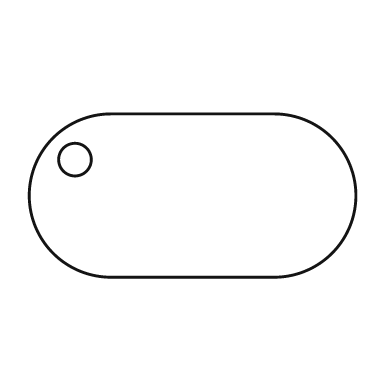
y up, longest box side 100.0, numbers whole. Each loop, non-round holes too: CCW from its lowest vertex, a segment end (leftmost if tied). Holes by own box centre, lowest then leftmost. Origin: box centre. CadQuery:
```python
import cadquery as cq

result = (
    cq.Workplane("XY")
    .moveTo(-25.0, -25.0)
    .lineTo(25.0, -25.0)
    .threePointArc((50.0, 0.0), (25.0, 25.0))
    .lineTo(-25.0, 25.0)
    .threePointArc((-50.0, 0.0), (-25.0, -25.0))
    .close()
    .moveTo(-36.0, 11.0)
    .circle(5.0)
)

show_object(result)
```